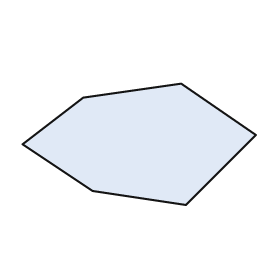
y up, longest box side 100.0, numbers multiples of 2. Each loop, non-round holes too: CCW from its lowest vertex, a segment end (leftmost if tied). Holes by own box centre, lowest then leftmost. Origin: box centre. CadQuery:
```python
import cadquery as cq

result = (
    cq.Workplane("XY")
    .moveTo(20.0, -26.0)
    .lineTo(50.0, 4.0)
    .lineTo(18.0, 26.0)
    .lineTo(-24.0, 20.0)
    .lineTo(-50.0, 0.0)
    .lineTo(-20.0, -20.0)
    .close()
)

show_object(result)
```